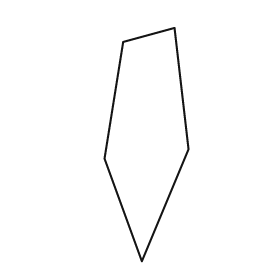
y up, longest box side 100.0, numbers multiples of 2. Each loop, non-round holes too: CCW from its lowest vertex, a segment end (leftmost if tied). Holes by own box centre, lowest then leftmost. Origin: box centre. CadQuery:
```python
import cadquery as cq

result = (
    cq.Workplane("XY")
    .moveTo(-2.0, -50.0)
    .lineTo(18.0, -2.0)
    .lineTo(12.0, 50.0)
    .lineTo(-10.0, 44.0)
    .lineTo(-18.0, -6.0)
    .close()
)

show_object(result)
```